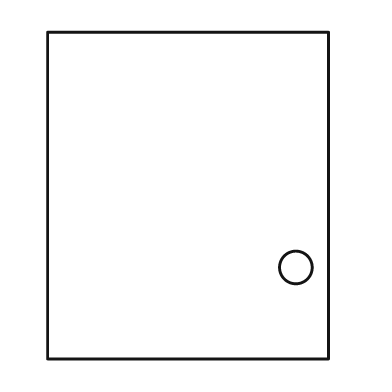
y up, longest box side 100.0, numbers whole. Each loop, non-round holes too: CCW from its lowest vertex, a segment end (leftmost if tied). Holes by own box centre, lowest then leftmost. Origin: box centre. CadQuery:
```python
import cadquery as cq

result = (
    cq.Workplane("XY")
    .moveTo(-43.0, -50.0)
    .lineTo(43.0, -50.0)
    .lineTo(43.0, 50.0)
    .lineTo(-43.0, 50.0)
    .close()
    .moveTo(33.0, -22.0)
    .circle(5.0)
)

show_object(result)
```